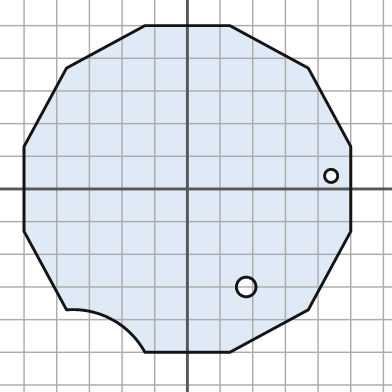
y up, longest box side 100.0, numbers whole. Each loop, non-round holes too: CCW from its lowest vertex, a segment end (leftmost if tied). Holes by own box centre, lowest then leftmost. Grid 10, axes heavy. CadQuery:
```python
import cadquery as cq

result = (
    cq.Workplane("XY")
    .moveTo(-13.0, -50.0)
    .lineTo(13.0, -50.0)
    .lineTo(37.0, -37.0)
    .lineTo(50.0, -13.0)
    .lineTo(50.0, 13.0)
    .lineTo(37.0, 37.0)
    .lineTo(13.0, 50.0)
    .lineTo(-13.0, 50.0)
    .lineTo(-37.0, 37.0)
    .lineTo(-50.0, 13.0)
    .lineTo(-50.0, -13.0)
    .lineTo(-37.0, -37.0)
    .threePointArc((-23.0, -40.0), (-13.0, -50.0))
    .close()
    .moveTo(18.0, -30.0)
    .circle(3.0)
    .moveTo(44.0, 4.0)
    .circle(2.0)
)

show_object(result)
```